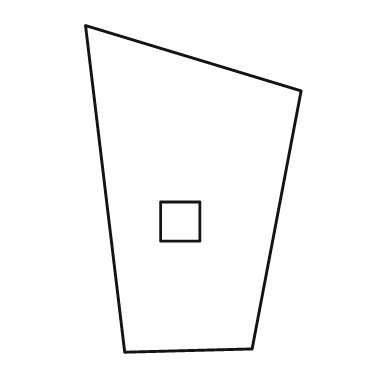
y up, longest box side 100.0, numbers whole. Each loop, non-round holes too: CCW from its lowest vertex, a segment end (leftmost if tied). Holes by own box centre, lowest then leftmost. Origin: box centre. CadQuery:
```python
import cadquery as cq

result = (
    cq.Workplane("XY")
    .moveTo(-21.0, -50.0)
    .lineTo(18.0, -49.0)
    .lineTo(33.0, 30.0)
    .lineTo(-33.0, 50.0)
    .close()
    .moveTo(-10.0, -16.0)
    .lineTo(2.0, -16.0)
    .lineTo(2.0, -4.0)
    .lineTo(-10.0, -4.0)
    .close()
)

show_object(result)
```